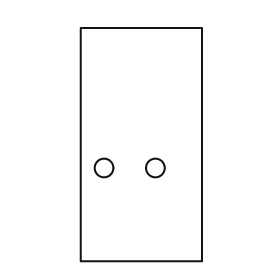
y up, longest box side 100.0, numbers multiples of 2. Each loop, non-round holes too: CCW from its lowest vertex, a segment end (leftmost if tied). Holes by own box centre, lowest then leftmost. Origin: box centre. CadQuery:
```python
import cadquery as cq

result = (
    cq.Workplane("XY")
    .moveTo(-26.0, -50.0)
    .lineTo(26.0, -50.0)
    .lineTo(26.0, 50.0)
    .lineTo(-26.0, 50.0)
    .close()
    .moveTo(-16.0, -10.0)
    .circle(4.0)
    .moveTo(6.0, -10.0)
    .circle(4.0)
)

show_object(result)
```